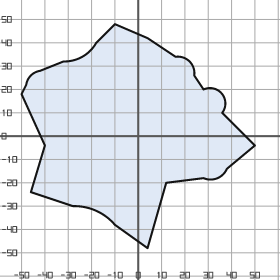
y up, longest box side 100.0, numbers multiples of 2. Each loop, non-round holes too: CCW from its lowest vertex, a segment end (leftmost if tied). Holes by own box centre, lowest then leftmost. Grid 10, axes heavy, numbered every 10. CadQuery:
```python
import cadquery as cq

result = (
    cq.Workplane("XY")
    .moveTo(4.0, -48.0)
    .lineTo(12.0, -20.0)
    .lineTo(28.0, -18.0)
    .threePointArc((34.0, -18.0), (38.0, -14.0))
    .lineTo(50.0, -4.0)
    .lineTo(36.0, 10.0)
    .threePointArc((36.0, 18.0), (28.0, 20.0))
    .lineTo(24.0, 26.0)
    .threePointArc((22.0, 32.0), (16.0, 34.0))
    .lineTo(4.0, 42.0)
    .lineTo(-10.0, 48.0)
    .lineTo(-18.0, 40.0)
    .threePointArc((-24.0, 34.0), (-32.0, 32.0))
    .lineTo(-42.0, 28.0)
    .threePointArc((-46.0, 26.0), (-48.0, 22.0))
    .lineTo(-50.0, 18.0)
    .lineTo(-40.0, -4.0)
    .lineTo(-46.0, -24.0)
    .lineTo(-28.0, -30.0)
    .threePointArc((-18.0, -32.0), (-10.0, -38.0))
    .close()
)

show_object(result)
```